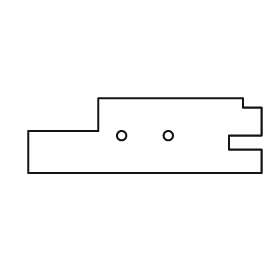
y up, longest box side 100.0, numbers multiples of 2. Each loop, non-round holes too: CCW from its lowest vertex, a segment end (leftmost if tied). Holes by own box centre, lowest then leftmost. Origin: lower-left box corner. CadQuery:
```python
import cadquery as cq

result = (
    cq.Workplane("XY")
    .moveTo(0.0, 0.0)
    .lineTo(100.0, 0.0)
    .lineTo(100.0, 10.0)
    .lineTo(86.0, 10.0)
    .lineTo(86.0, 16.0)
    .lineTo(100.0, 16.0)
    .lineTo(100.0, 28.0)
    .lineTo(92.0, 28.0)
    .lineTo(92.0, 32.0)
    .lineTo(30.0, 32.0)
    .lineTo(30.0, 18.0)
    .lineTo(0.0, 18.0)
    .close()
    .moveTo(40.0, 16.0)
    .circle(2.0)
    .moveTo(60.0, 16.0)
    .circle(2.0)
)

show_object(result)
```